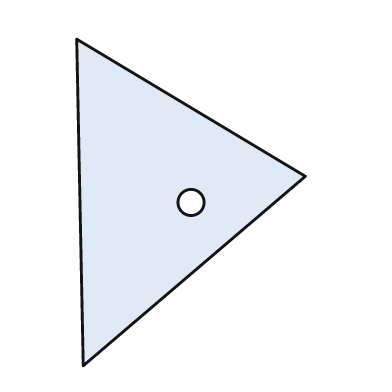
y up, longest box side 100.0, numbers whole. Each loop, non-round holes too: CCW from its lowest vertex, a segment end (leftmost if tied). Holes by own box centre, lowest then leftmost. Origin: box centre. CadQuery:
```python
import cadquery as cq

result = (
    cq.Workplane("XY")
    .moveTo(-33.0, -50.0)
    .lineTo(35.0, 8.0)
    .lineTo(-35.0, 50.0)
    .close()
    .moveTo(0.0, 0.0)
    .circle(4.0)
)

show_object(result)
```